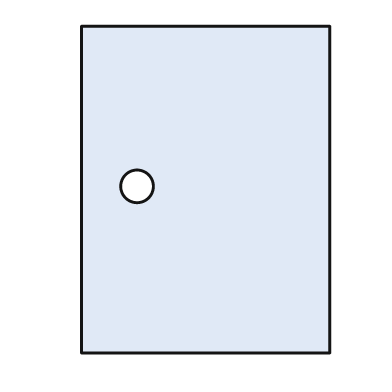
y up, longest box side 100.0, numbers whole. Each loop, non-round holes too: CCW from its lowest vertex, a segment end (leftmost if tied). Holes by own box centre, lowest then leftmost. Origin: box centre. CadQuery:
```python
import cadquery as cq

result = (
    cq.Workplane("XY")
    .moveTo(-38.0, -50.0)
    .lineTo(38.0, -50.0)
    .lineTo(38.0, 50.0)
    .lineTo(-38.0, 50.0)
    .close()
    .moveTo(-21.0, 1.0)
    .circle(5.0)
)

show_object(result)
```